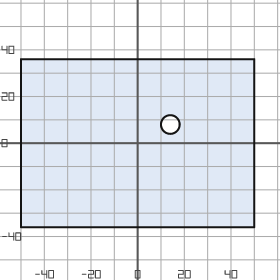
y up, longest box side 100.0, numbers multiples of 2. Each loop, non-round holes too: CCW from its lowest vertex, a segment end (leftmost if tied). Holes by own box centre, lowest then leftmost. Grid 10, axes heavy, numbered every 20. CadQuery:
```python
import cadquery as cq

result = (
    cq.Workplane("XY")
    .moveTo(-50.0, -36.0)
    .lineTo(50.0, -36.0)
    .lineTo(50.0, 36.0)
    .lineTo(-50.0, 36.0)
    .close()
    .moveTo(14.0, 8.0)
    .circle(4.0)
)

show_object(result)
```